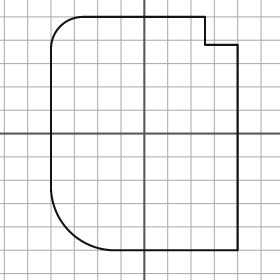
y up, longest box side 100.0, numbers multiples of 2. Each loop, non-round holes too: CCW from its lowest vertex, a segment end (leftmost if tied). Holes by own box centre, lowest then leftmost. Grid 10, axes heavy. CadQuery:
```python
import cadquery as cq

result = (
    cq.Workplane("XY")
    .moveTo(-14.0, -50.0)
    .lineTo(40.0, -50.0)
    .lineTo(40.0, 38.0)
    .lineTo(26.0, 38.0)
    .lineTo(26.0, 50.0)
    .lineTo(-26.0, 50.0)
    .threePointArc((-36.0, 46.0), (-40.0, 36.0))
    .lineTo(-40.0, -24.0)
    .threePointArc((-32.0, -42.0), (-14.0, -50.0))
    .close()
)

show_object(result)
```